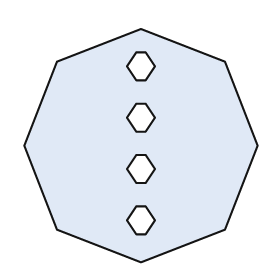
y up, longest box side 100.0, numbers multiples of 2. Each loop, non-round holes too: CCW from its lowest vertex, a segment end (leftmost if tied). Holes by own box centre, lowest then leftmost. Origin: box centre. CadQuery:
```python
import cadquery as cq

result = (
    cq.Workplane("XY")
    .moveTo(0.0, -50.0)
    .lineTo(36.0, -36.0)
    .lineTo(50.0, 0.0)
    .lineTo(36.0, 36.0)
    .lineTo(0.0, 50.0)
    .lineTo(-36.0, 36.0)
    .lineTo(-50.0, 0.0)
    .lineTo(-36.0, -36.0)
    .close()
    .moveTo(-2.0, -38.0)
    .lineTo(2.0, -38.0)
    .lineTo(6.0, -32.0)
    .lineTo(2.0, -26.0)
    .lineTo(-2.0, -26.0)
    .lineTo(-6.0, -32.0)
    .close()
    .moveTo(-2.0, -16.0)
    .lineTo(2.0, -16.0)
    .lineTo(6.0, -10.0)
    .lineTo(2.0, -4.0)
    .lineTo(-2.0, -4.0)
    .lineTo(-6.0, -10.0)
    .close()
    .moveTo(-2.0, 6.0)
    .lineTo(2.0, 6.0)
    .lineTo(6.0, 12.0)
    .lineTo(2.0, 18.0)
    .lineTo(-2.0, 18.0)
    .lineTo(-6.0, 12.0)
    .close()
    .moveTo(-2.0, 28.0)
    .lineTo(2.0, 28.0)
    .lineTo(6.0, 34.0)
    .lineTo(2.0, 40.0)
    .lineTo(-2.0, 40.0)
    .lineTo(-6.0, 34.0)
    .close()
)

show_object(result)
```